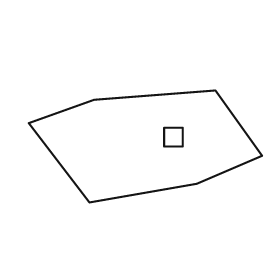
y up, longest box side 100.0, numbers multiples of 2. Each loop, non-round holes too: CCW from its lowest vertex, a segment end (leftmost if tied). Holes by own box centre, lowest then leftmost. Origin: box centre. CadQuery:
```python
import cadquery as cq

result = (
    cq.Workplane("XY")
    .moveTo(-24.0, -24.0)
    .lineTo(22.0, -16.0)
    .lineTo(50.0, -4.0)
    .lineTo(30.0, 24.0)
    .lineTo(-22.0, 20.0)
    .lineTo(-50.0, 10.0)
    .close()
    .moveTo(8.0, 0.0)
    .lineTo(16.0, 0.0)
    .lineTo(16.0, 8.0)
    .lineTo(8.0, 8.0)
    .close()
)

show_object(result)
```